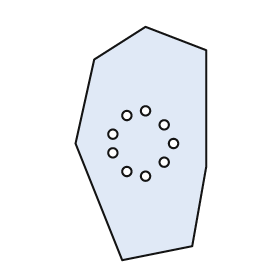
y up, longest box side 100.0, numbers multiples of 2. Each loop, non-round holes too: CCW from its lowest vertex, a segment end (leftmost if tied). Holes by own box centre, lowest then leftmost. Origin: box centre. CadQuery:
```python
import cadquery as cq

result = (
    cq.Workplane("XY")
    .moveTo(-8.0, -50.0)
    .lineTo(22.0, -44.0)
    .lineTo(28.0, -10.0)
    .lineTo(28.0, 40.0)
    .lineTo(2.0, 50.0)
    .lineTo(-20.0, 36.0)
    .lineTo(-28.0, 0.0)
    .close()
    .moveTo(2.0, -14.0)
    .circle(2.0)
    .moveTo(-6.0, -12.0)
    .circle(2.0)
    .moveTo(10.0, -8.0)
    .circle(2.0)
    .moveTo(-12.0, -4.0)
    .circle(2.0)
    .moveTo(14.0, 0.0)
    .circle(2.0)
    .moveTo(-12.0, 4.0)
    .circle(2.0)
    .moveTo(10.0, 8.0)
    .circle(2.0)
    .moveTo(-6.0, 12.0)
    .circle(2.0)
    .moveTo(2.0, 14.0)
    .circle(2.0)
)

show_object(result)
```